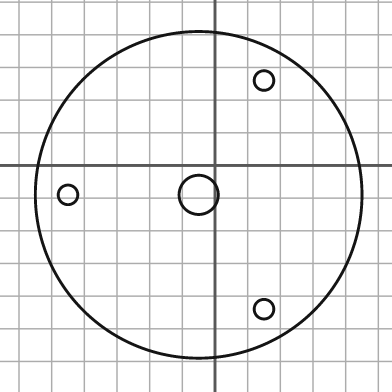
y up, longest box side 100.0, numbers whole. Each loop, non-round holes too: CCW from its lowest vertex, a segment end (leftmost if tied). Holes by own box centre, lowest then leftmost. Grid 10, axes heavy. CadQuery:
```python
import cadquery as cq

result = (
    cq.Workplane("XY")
    .moveTo(-5.0, -9.0)
    .circle(50.0)
    .moveTo(15.0, -44.0)
    .circle(3.0)
    .moveTo(-45.0, -9.0)
    .circle(3.0)
    .moveTo(-5.0, -9.0)
    .circle(6.0)
    .moveTo(15.0, 26.0)
    .circle(3.0)
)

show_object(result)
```